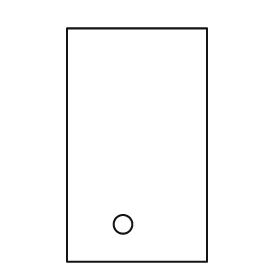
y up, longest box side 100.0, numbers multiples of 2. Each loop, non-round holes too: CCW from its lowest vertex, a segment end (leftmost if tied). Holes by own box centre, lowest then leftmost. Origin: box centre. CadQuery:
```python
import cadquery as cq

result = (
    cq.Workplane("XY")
    .moveTo(-30.0, -50.0)
    .lineTo(30.0, -50.0)
    .lineTo(30.0, 50.0)
    .lineTo(-30.0, 50.0)
    .close()
    .moveTo(-6.0, -34.0)
    .circle(4.0)
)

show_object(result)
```